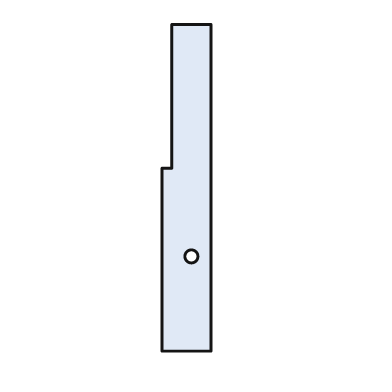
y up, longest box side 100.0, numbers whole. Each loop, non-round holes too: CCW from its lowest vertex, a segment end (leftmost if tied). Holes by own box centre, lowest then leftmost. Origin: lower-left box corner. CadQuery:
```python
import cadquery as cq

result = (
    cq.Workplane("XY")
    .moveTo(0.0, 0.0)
    .lineTo(15.0, 0.0)
    .lineTo(15.0, 100.0)
    .lineTo(3.0, 100.0)
    .lineTo(3.0, 56.0)
    .lineTo(0.0, 56.0)
    .close()
    .moveTo(9.0, 29.0)
    .circle(2.0)
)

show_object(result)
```